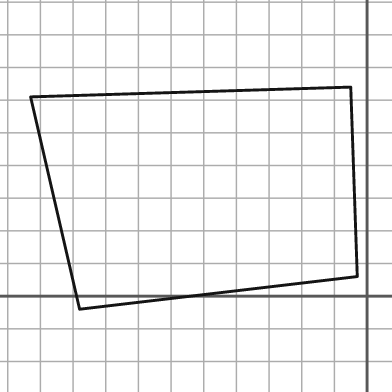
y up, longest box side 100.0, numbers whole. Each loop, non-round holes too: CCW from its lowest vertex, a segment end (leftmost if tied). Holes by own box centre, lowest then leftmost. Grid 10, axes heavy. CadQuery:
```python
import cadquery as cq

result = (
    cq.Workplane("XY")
    .moveTo(-88.0, -4.0)
    .lineTo(-3.0, 6.0)
    .lineTo(-5.0, 64.0)
    .lineTo(-103.0, 61.0)
    .close()
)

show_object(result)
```